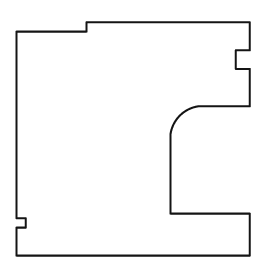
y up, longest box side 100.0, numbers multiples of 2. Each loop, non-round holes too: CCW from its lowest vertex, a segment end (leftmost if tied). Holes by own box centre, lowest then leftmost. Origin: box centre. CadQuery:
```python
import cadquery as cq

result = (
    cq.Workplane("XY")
    .moveTo(-50.0, -50.0)
    .lineTo(50.0, -50.0)
    .lineTo(50.0, -32.0)
    .lineTo(16.0, -32.0)
    .lineTo(16.0, 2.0)
    .threePointArc((20.0, 10.0), (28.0, 14.0))
    .lineTo(50.0, 14.0)
    .lineTo(50.0, 30.0)
    .lineTo(44.0, 30.0)
    .lineTo(44.0, 38.0)
    .lineTo(50.0, 38.0)
    .lineTo(50.0, 50.0)
    .lineTo(-20.0, 50.0)
    .lineTo(-20.0, 46.0)
    .lineTo(-50.0, 46.0)
    .lineTo(-50.0, -34.0)
    .lineTo(-46.0, -34.0)
    .lineTo(-46.0, -38.0)
    .lineTo(-50.0, -38.0)
    .close()
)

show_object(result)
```